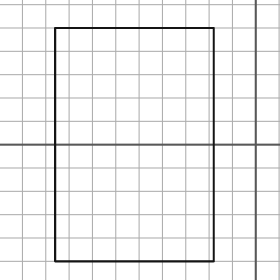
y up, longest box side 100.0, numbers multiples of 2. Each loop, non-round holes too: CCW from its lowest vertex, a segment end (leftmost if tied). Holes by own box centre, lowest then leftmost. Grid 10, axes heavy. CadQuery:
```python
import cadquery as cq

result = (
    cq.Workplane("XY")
    .moveTo(-86.0, -50.0)
    .lineTo(-18.0, -50.0)
    .lineTo(-18.0, 50.0)
    .lineTo(-86.0, 50.0)
    .close()
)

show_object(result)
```